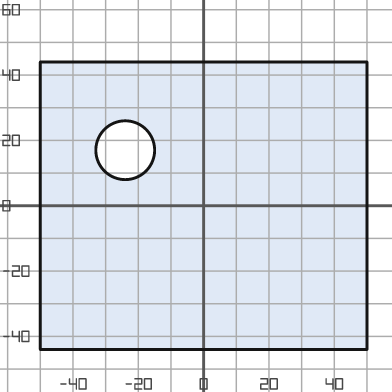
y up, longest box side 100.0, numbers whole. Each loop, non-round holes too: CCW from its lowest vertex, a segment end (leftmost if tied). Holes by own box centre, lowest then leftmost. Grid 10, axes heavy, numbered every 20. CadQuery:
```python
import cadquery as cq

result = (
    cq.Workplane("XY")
    .moveTo(-50.0, -44.0)
    .lineTo(50.0, -44.0)
    .lineTo(50.0, 44.0)
    .lineTo(-50.0, 44.0)
    .close()
    .moveTo(-24.0, 17.0)
    .circle(9.0)
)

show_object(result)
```